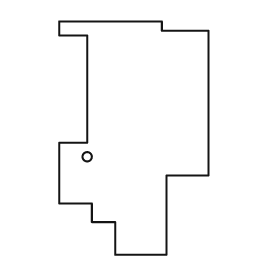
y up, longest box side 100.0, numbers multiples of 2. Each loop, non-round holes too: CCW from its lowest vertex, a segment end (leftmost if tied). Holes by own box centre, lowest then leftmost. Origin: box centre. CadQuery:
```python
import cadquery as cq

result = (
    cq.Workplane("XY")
    .moveTo(-8.0, -50.0)
    .lineTo(14.0, -50.0)
    .lineTo(14.0, -16.0)
    .lineTo(32.0, -16.0)
    .lineTo(32.0, 46.0)
    .lineTo(12.0, 46.0)
    .lineTo(12.0, 50.0)
    .lineTo(-32.0, 50.0)
    .lineTo(-32.0, 44.0)
    .lineTo(-20.0, 44.0)
    .lineTo(-20.0, -2.0)
    .lineTo(-32.0, -2.0)
    .lineTo(-32.0, -28.0)
    .lineTo(-18.0, -28.0)
    .lineTo(-18.0, -36.0)
    .lineTo(-8.0, -36.0)
    .close()
    .moveTo(-20.0, -8.0)
    .circle(2.0)
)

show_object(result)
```